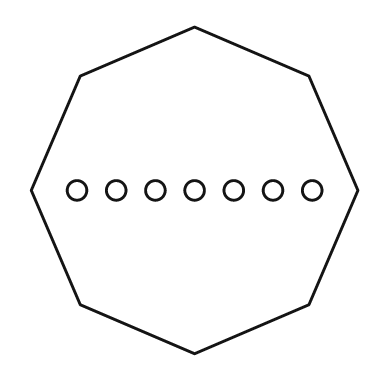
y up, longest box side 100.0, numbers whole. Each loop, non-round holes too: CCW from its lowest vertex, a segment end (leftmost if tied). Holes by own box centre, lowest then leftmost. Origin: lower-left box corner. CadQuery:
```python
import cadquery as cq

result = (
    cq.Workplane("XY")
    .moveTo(50.0, 0.0)
    .lineTo(85.0, 15.0)
    .lineTo(100.0, 50.0)
    .lineTo(85.0, 85.0)
    .lineTo(50.0, 100.0)
    .lineTo(15.0, 85.0)
    .lineTo(0.0, 50.0)
    .lineTo(15.0, 15.0)
    .close()
    .moveTo(14.0, 50.0)
    .circle(3.0)
    .moveTo(26.0, 50.0)
    .circle(3.0)
    .moveTo(38.0, 50.0)
    .circle(3.0)
    .moveTo(50.0, 50.0)
    .circle(3.0)
    .moveTo(62.0, 50.0)
    .circle(3.0)
    .moveTo(74.0, 50.0)
    .circle(3.0)
    .moveTo(86.0, 50.0)
    .circle(3.0)
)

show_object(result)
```